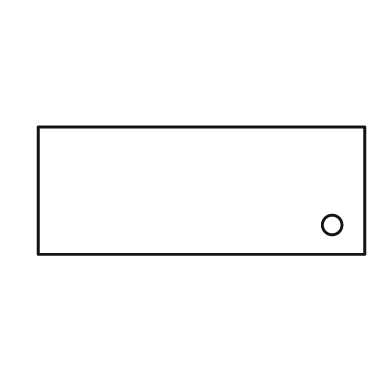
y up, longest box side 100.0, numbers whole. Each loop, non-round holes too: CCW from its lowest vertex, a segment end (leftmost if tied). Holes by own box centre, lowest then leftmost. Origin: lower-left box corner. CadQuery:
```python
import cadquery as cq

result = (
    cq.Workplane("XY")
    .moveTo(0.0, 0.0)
    .lineTo(100.0, 0.0)
    .lineTo(100.0, 39.0)
    .lineTo(0.0, 39.0)
    .close()
    .moveTo(90.0, 9.0)
    .circle(3.0)
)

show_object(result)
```